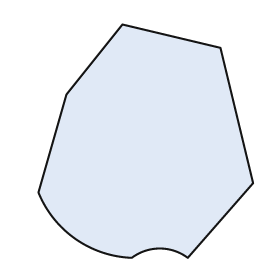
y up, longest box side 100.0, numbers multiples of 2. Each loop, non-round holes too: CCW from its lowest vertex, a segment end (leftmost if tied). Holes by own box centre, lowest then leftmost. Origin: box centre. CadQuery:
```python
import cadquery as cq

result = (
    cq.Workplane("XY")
    .moveTo(-6.0, -50.0)
    .threePointArc((6.0, -46.0), (18.0, -50.0))
    .lineTo(46.0, -18.0)
    .lineTo(32.0, 40.0)
    .lineTo(-10.0, 50.0)
    .lineTo(-34.0, 20.0)
    .lineTo(-46.0, -22.0)
    .threePointArc((-30.0, -42.0), (-6.0, -50.0))
    .close()
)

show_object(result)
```